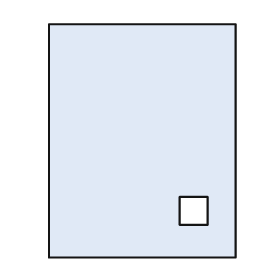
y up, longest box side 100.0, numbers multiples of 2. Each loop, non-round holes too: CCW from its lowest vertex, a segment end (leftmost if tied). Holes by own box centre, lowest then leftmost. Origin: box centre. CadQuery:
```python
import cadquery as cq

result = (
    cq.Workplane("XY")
    .moveTo(-40.0, -50.0)
    .lineTo(40.0, -50.0)
    .lineTo(40.0, 50.0)
    .lineTo(-40.0, 50.0)
    .close()
    .moveTo(16.0, -36.0)
    .lineTo(28.0, -36.0)
    .lineTo(28.0, -24.0)
    .lineTo(16.0, -24.0)
    .close()
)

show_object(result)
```